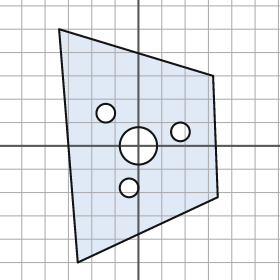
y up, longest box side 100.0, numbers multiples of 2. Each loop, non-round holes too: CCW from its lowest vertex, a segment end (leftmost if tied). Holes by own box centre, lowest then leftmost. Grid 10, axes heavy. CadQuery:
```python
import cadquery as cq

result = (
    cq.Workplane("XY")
    .moveTo(-26.0, -50.0)
    .lineTo(34.0, -22.0)
    .lineTo(32.0, 30.0)
    .lineTo(-34.0, 50.0)
    .close()
    .moveTo(-4.0, -18.0)
    .circle(4.0)
    .moveTo(0.0, 0.0)
    .circle(8.0)
    .moveTo(18.0, 6.0)
    .circle(4.0)
    .moveTo(-14.0, 14.0)
    .circle(4.0)
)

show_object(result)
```